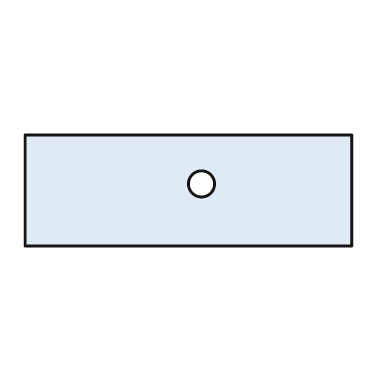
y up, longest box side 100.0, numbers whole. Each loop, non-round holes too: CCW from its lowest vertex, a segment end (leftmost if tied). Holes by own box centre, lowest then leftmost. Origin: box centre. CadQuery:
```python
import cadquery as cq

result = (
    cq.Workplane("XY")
    .moveTo(-50.0, -17.0)
    .lineTo(50.0, -17.0)
    .lineTo(50.0, 17.0)
    .lineTo(-50.0, 17.0)
    .close()
    .moveTo(4.0, 2.0)
    .circle(4.0)
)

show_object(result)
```